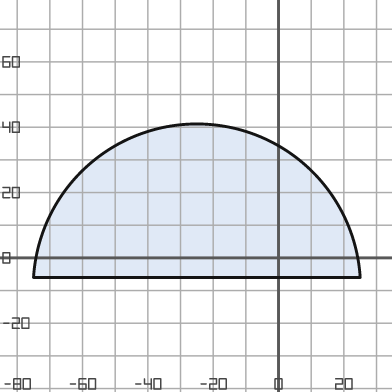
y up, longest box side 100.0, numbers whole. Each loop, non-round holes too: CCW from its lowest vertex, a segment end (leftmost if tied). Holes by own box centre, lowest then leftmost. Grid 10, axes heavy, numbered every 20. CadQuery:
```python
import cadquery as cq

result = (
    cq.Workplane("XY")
    .moveTo(-75.0, -6.0)
    .lineTo(25.0, -6.0)
    .threePointArc((-25.0, 41.0), (-75.0, -6.0))
    .close()
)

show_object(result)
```